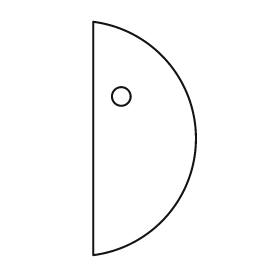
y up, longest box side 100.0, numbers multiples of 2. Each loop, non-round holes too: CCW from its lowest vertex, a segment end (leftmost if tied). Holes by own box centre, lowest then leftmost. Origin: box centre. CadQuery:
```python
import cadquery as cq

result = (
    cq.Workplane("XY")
    .moveTo(-22.0, -50.0)
    .threePointArc((22.0, 0.0), (-22.0, 50.0))
    .close()
    .moveTo(-10.0, 18.0)
    .circle(4.0)
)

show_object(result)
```